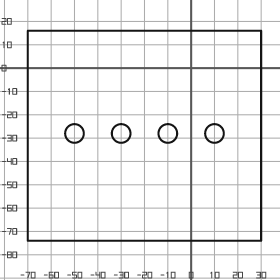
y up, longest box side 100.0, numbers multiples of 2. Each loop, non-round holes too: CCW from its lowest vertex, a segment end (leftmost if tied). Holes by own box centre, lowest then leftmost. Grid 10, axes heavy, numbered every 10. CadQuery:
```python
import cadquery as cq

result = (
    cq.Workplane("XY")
    .moveTo(-70.0, -74.0)
    .lineTo(30.0, -74.0)
    .lineTo(30.0, 16.0)
    .lineTo(-70.0, 16.0)
    .close()
    .moveTo(-50.0, -28.0)
    .circle(4.0)
    .moveTo(-30.0, -28.0)
    .circle(4.0)
    .moveTo(-10.0, -28.0)
    .circle(4.0)
    .moveTo(10.0, -28.0)
    .circle(4.0)
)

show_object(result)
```